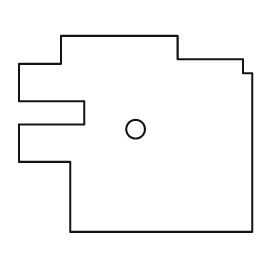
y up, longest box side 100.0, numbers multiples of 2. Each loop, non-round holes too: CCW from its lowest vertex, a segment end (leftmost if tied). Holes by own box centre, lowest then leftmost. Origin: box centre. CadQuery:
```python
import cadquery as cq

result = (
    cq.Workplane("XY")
    .moveTo(-28.0, -42.0)
    .lineTo(50.0, -42.0)
    .lineTo(50.0, 26.0)
    .lineTo(46.0, 26.0)
    .lineTo(46.0, 32.0)
    .lineTo(18.0, 32.0)
    .lineTo(18.0, 42.0)
    .lineTo(-32.0, 42.0)
    .lineTo(-32.0, 30.0)
    .lineTo(-50.0, 30.0)
    .lineTo(-50.0, 14.0)
    .lineTo(-22.0, 14.0)
    .lineTo(-22.0, 4.0)
    .lineTo(-50.0, 4.0)
    .lineTo(-50.0, -12.0)
    .lineTo(-28.0, -12.0)
    .close()
    .moveTo(0.0, 2.0)
    .circle(4.0)
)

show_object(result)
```